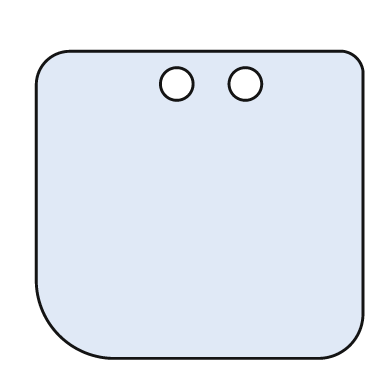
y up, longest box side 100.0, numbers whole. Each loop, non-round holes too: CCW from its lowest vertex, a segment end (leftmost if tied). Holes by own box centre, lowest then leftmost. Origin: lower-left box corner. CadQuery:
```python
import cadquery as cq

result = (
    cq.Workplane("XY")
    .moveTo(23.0, 0.0)
    .lineTo(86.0, 0.0)
    .threePointArc((96.0, 4.0), (100.0, 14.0))
    .lineTo(100.0, 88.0)
    .threePointArc((98.0, 92.0), (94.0, 94.0))
    .lineTo(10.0, 94.0)
    .threePointArc((3.0, 91.0), (0.0, 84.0))
    .lineTo(0.0, 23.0)
    .threePointArc((7.0, 7.0), (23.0, 0.0))
    .close()
    .moveTo(43.0, 84.0)
    .circle(5.0)
    .moveTo(64.0, 84.0)
    .circle(5.0)
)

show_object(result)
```